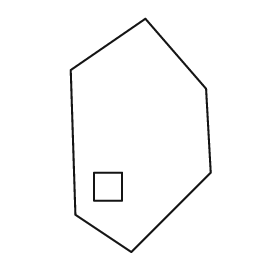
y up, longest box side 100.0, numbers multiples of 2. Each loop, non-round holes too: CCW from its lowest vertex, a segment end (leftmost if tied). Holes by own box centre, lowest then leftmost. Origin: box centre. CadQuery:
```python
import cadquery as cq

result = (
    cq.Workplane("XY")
    .moveTo(-4.0, -50.0)
    .lineTo(30.0, -16.0)
    .lineTo(28.0, 20.0)
    .lineTo(2.0, 50.0)
    .lineTo(-30.0, 28.0)
    .lineTo(-28.0, -34.0)
    .close()
    .moveTo(-20.0, -28.0)
    .lineTo(-8.0, -28.0)
    .lineTo(-8.0, -16.0)
    .lineTo(-20.0, -16.0)
    .close()
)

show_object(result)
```